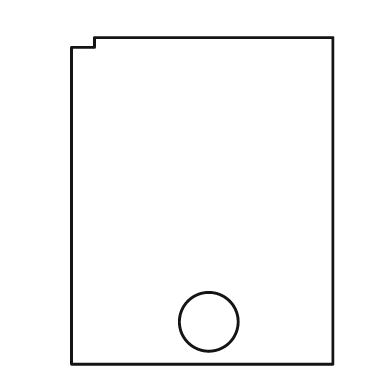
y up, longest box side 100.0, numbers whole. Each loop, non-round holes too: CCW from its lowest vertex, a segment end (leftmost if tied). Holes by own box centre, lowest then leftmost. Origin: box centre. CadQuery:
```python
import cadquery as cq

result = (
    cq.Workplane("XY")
    .moveTo(-40.0, -50.0)
    .lineTo(40.0, -50.0)
    .lineTo(40.0, 50.0)
    .lineTo(-33.0, 50.0)
    .lineTo(-33.0, 47.0)
    .lineTo(-40.0, 47.0)
    .close()
    .moveTo(2.0, -37.0)
    .circle(9.0)
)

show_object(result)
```